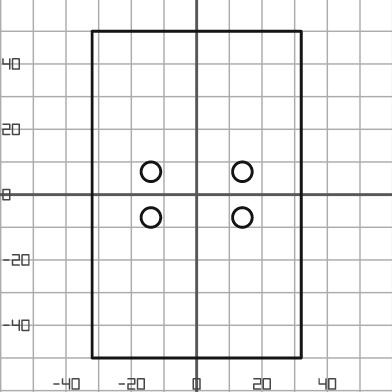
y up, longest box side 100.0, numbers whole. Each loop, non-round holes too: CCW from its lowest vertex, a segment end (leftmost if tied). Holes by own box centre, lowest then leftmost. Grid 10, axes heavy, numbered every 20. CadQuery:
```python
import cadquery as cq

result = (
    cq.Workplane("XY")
    .moveTo(-32.0, -50.0)
    .lineTo(32.0, -50.0)
    .lineTo(32.0, 50.0)
    .lineTo(-32.0, 50.0)
    .close()
    .moveTo(-14.0, -7.0)
    .circle(3.0)
    .moveTo(14.0, -7.0)
    .circle(3.0)
    .moveTo(-14.0, 7.0)
    .circle(3.0)
    .moveTo(14.0, 7.0)
    .circle(3.0)
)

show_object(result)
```